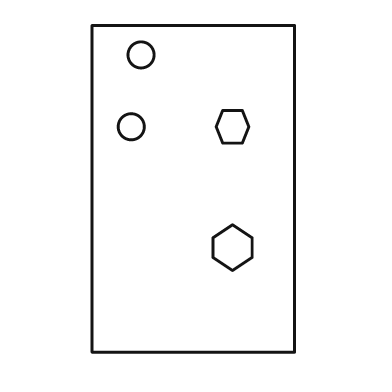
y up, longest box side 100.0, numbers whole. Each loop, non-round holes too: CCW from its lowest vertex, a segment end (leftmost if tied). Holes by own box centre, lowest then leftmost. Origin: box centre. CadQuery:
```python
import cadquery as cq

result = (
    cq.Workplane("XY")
    .moveTo(-31.0, -50.0)
    .lineTo(31.0, -50.0)
    .lineTo(31.0, 50.0)
    .lineTo(-31.0, 50.0)
    .close()
    .moveTo(12.0, -25.0)
    .lineTo(18.0, -21.0)
    .lineTo(18.0, -15.0)
    .lineTo(12.0, -11.0)
    .lineTo(6.0, -15.0)
    .lineTo(6.0, -21.0)
    .close()
    .moveTo(-19.0, 19.0)
    .circle(4.0)
    .moveTo(9.0, 14.0)
    .lineTo(15.0, 14.0)
    .lineTo(17.0, 19.0)
    .lineTo(15.0, 24.0)
    .lineTo(9.0, 24.0)
    .lineTo(7.0, 19.0)
    .close()
    .moveTo(-16.0, 41.0)
    .circle(4.0)
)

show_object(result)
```